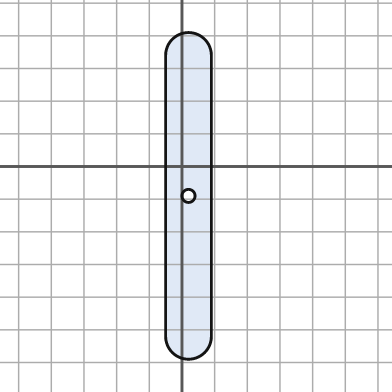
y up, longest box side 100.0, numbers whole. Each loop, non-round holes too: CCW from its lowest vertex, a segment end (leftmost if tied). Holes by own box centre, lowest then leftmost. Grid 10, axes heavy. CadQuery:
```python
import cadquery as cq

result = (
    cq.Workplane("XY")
    .moveTo(-5.0, -52.0)
    .threePointArc((2.0, -59.0), (9.0, -52.0))
    .lineTo(9.0, 34.0)
    .threePointArc((2.0, 41.0), (-5.0, 34.0))
    .close()
    .moveTo(2.0, -9.0)
    .circle(2.0)
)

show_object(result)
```